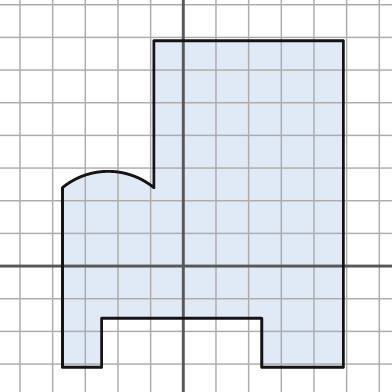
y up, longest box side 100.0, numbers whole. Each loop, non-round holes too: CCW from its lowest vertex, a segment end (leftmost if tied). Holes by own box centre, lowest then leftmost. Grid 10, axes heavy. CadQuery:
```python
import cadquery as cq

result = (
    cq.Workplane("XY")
    .moveTo(-37.0, -31.0)
    .lineTo(-25.0, -31.0)
    .lineTo(-25.0, -16.0)
    .lineTo(24.0, -16.0)
    .lineTo(24.0, -31.0)
    .lineTo(49.0, -31.0)
    .lineTo(49.0, 69.0)
    .lineTo(-9.0, 69.0)
    .lineTo(-9.0, 24.0)
    .threePointArc((-23.0, 29.0), (-37.0, 24.0))
    .close()
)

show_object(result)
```